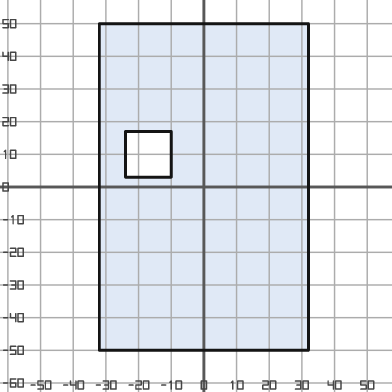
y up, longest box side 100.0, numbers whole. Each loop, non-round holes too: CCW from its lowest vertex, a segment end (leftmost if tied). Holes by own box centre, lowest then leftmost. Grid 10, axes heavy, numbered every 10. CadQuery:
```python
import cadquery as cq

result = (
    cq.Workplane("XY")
    .moveTo(-32.0, -50.0)
    .lineTo(32.0, -50.0)
    .lineTo(32.0, 50.0)
    .lineTo(-32.0, 50.0)
    .close()
    .moveTo(-24.0, 3.0)
    .lineTo(-10.0, 3.0)
    .lineTo(-10.0, 17.0)
    .lineTo(-24.0, 17.0)
    .close()
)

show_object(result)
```